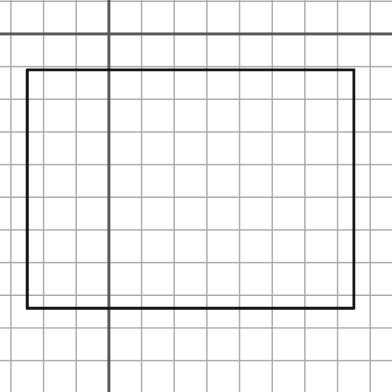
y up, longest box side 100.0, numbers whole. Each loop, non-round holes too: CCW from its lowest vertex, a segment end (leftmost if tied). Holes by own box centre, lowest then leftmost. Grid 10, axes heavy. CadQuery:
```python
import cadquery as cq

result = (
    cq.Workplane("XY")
    .moveTo(-25.0, -84.0)
    .lineTo(75.0, -84.0)
    .lineTo(75.0, -11.0)
    .lineTo(-25.0, -11.0)
    .close()
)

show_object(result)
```